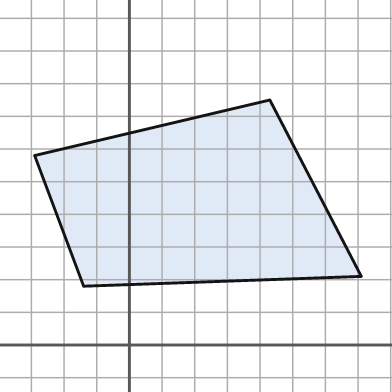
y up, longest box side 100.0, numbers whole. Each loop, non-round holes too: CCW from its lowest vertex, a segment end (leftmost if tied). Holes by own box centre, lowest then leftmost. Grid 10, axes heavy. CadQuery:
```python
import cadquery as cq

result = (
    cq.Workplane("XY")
    .moveTo(-14.0, 18.0)
    .lineTo(71.0, 21.0)
    .lineTo(43.0, 75.0)
    .lineTo(-29.0, 58.0)
    .close()
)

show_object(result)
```